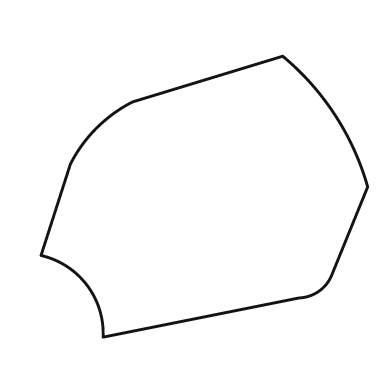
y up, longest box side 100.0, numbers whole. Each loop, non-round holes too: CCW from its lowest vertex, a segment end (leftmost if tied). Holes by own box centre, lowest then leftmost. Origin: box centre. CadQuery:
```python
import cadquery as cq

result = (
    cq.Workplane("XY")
    .moveTo(-31.0, -43.0)
    .lineTo(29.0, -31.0)
    .threePointArc((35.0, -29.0), (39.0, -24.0))
    .lineTo(50.0, 3.0)
    .threePointArc((40.0, 25.0), (24.0, 43.0))
    .lineTo(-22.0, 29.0)
    .threePointArc((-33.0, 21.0), (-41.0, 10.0))
    .lineTo(-50.0, -18.0)
    .threePointArc((-36.0, -27.0), (-31.0, -43.0))
    .close()
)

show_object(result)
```